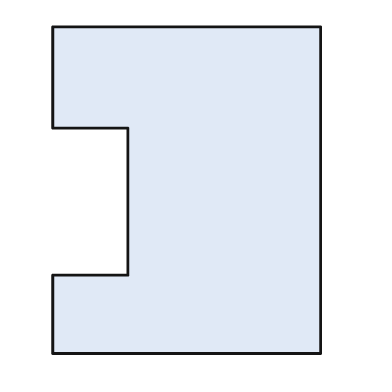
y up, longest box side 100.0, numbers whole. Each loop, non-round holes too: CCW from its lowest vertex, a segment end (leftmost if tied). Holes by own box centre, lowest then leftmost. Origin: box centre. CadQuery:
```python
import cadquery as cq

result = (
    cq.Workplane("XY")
    .moveTo(-41.0, -50.0)
    .lineTo(41.0, -50.0)
    .lineTo(41.0, 50.0)
    .lineTo(-41.0, 50.0)
    .lineTo(-41.0, 19.0)
    .lineTo(-18.0, 19.0)
    .lineTo(-18.0, -26.0)
    .lineTo(-41.0, -26.0)
    .close()
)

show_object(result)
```